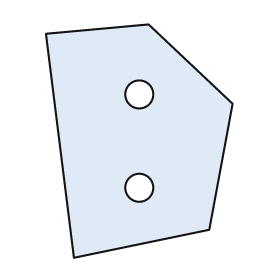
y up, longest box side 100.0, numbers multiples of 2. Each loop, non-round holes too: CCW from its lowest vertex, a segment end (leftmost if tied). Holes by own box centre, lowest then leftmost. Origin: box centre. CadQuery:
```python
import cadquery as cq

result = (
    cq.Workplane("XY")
    .moveTo(-28.0, -50.0)
    .lineTo(30.0, -38.0)
    .lineTo(40.0, 16.0)
    .lineTo(4.0, 50.0)
    .lineTo(-40.0, 46.0)
    .close()
    .moveTo(0.0, -20.0)
    .circle(6.0)
    .moveTo(0.0, 20.0)
    .circle(6.0)
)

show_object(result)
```